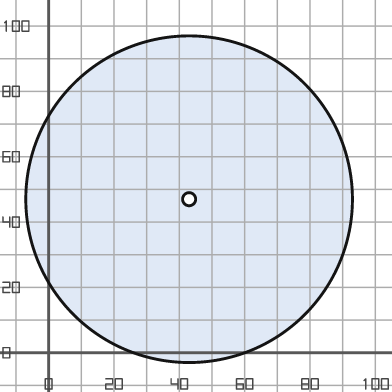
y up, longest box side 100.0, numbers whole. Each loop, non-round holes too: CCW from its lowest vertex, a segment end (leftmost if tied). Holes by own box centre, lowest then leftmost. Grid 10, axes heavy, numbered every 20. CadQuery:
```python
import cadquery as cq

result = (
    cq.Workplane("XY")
    .moveTo(43.0, 47.0)
    .circle(50.0)
    .moveTo(43.0, 47.0)
    .circle(2.0)
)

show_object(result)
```